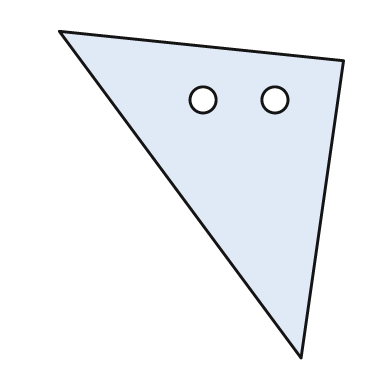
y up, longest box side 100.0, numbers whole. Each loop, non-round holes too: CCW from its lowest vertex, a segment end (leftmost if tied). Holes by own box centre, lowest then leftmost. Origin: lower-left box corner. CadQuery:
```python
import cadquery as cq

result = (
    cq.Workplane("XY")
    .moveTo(74.0, 0.0)
    .lineTo(87.0, 91.0)
    .lineTo(0.0, 100.0)
    .close()
    .moveTo(44.0, 79.0)
    .circle(4.0)
    .moveTo(66.0, 79.0)
    .circle(4.0)
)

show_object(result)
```